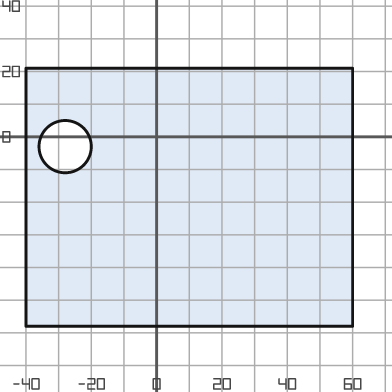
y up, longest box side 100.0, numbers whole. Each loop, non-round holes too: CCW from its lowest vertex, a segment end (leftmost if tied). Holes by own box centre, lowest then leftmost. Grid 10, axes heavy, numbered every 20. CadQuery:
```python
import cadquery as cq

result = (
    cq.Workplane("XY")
    .moveTo(-40.0, -58.0)
    .lineTo(60.0, -58.0)
    .lineTo(60.0, 21.0)
    .lineTo(-40.0, 21.0)
    .close()
    .moveTo(-28.0, -3.0)
    .circle(8.0)
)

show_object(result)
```